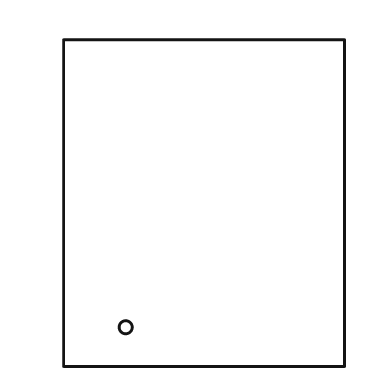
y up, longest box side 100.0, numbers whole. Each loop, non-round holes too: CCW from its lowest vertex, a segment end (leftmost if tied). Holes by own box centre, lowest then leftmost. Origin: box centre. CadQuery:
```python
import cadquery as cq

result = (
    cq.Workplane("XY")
    .moveTo(-43.0, -50.0)
    .lineTo(43.0, -50.0)
    .lineTo(43.0, 50.0)
    .lineTo(-43.0, 50.0)
    .close()
    .moveTo(-24.0, -38.0)
    .circle(2.0)
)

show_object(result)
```